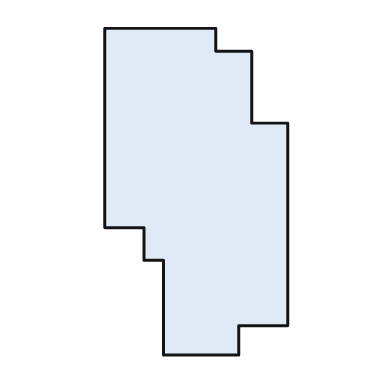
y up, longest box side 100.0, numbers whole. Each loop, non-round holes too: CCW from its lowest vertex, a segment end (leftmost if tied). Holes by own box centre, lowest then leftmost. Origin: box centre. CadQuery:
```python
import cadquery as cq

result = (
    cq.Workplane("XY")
    .moveTo(-10.0, -50.0)
    .lineTo(13.0, -50.0)
    .lineTo(13.0, -41.0)
    .lineTo(28.0, -41.0)
    .lineTo(28.0, 21.0)
    .lineTo(17.0, 21.0)
    .lineTo(17.0, 43.0)
    .lineTo(6.0, 43.0)
    .lineTo(6.0, 50.0)
    .lineTo(-28.0, 50.0)
    .lineTo(-28.0, -11.0)
    .lineTo(-16.0, -11.0)
    .lineTo(-16.0, -21.0)
    .lineTo(-10.0, -21.0)
    .close()
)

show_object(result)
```